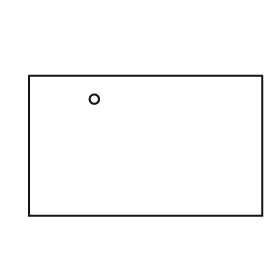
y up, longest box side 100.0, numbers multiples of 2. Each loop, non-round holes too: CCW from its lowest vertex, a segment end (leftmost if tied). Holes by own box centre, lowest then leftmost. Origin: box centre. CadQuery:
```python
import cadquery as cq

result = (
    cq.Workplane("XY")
    .moveTo(-50.0, -30.0)
    .lineTo(50.0, -30.0)
    .lineTo(50.0, 30.0)
    .lineTo(-50.0, 30.0)
    .close()
    .moveTo(-22.0, 20.0)
    .circle(2.0)
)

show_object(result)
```